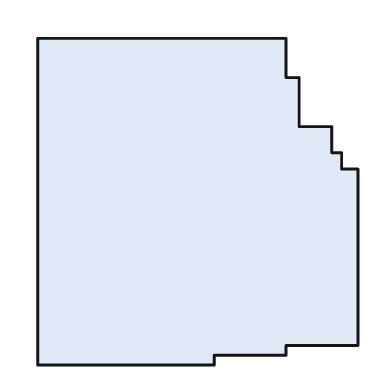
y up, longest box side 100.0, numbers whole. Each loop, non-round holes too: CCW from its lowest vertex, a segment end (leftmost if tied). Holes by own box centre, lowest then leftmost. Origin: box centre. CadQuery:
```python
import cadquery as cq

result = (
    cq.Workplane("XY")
    .moveTo(-49.0, -50.0)
    .lineTo(5.0, -50.0)
    .lineTo(5.0, -47.0)
    .lineTo(27.0, -47.0)
    .lineTo(27.0, -44.0)
    .lineTo(49.0, -44.0)
    .lineTo(49.0, 10.0)
    .lineTo(44.0, 10.0)
    .lineTo(44.0, 15.0)
    .lineTo(41.0, 15.0)
    .lineTo(41.0, 23.0)
    .lineTo(31.0, 23.0)
    .lineTo(31.0, 38.0)
    .lineTo(27.0, 38.0)
    .lineTo(27.0, 50.0)
    .lineTo(-49.0, 50.0)
    .close()
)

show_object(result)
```